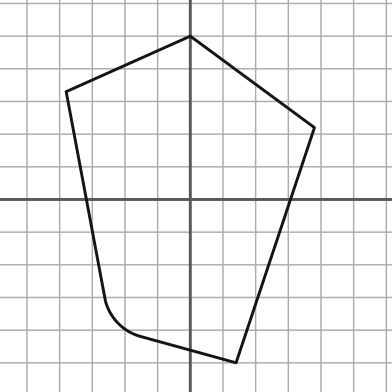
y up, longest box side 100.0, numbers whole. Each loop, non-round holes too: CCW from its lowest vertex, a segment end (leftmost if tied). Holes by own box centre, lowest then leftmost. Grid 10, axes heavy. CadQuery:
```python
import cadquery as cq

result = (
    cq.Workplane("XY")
    .moveTo(14.0, -50.0)
    .lineTo(38.0, 22.0)
    .lineTo(0.0, 50.0)
    .lineTo(-38.0, 33.0)
    .lineTo(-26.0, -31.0)
    .threePointArc((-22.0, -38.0), (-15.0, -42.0))
    .close()
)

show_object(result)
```